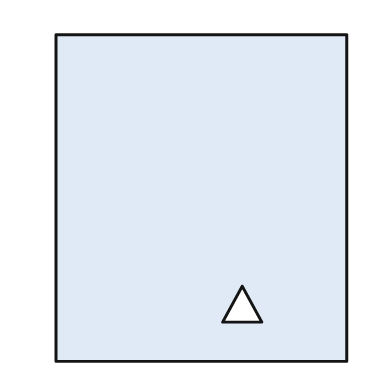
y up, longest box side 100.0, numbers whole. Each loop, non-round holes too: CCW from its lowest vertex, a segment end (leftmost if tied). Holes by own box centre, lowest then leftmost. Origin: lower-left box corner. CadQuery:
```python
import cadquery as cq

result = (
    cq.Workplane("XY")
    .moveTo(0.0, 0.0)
    .lineTo(89.0, 0.0)
    .lineTo(89.0, 100.0)
    .lineTo(0.0, 100.0)
    .close()
    .moveTo(51.0, 12.0)
    .lineTo(63.0, 12.0)
    .lineTo(57.0, 23.0)
    .close()
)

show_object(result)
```